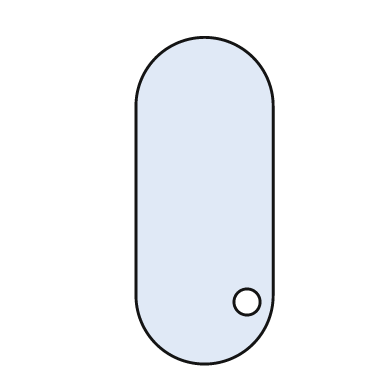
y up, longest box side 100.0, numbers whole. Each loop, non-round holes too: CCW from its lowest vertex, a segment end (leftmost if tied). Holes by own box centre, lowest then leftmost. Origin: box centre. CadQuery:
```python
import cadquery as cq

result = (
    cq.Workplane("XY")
    .moveTo(-21.0, -29.0)
    .threePointArc((0.0, -50.0), (21.0, -29.0))
    .lineTo(21.0, 29.0)
    .threePointArc((0.0, 50.0), (-21.0, 29.0))
    .close()
    .moveTo(13.0, -31.0)
    .circle(4.0)
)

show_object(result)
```